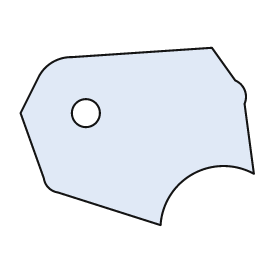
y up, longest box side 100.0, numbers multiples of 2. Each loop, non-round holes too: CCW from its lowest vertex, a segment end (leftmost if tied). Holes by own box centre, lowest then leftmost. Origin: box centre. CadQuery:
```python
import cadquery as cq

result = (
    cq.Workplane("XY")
    .moveTo(10.0, -38.0)
    .threePointArc((24.0, -16.0), (50.0, -16.0))
    .lineTo(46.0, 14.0)
    .threePointArc((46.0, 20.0), (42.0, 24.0))
    .lineTo(32.0, 38.0)
    .lineTo(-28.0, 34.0)
    .threePointArc((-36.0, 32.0), (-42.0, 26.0))
    .lineTo(-50.0, 10.0)
    .lineTo(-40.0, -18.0)
    .threePointArc((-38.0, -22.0), (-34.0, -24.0))
    .close()
    .moveTo(-22.0, 10.0)
    .circle(6.0)
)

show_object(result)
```